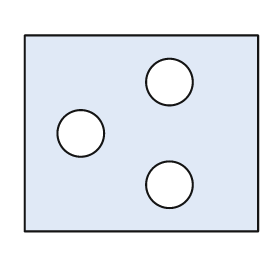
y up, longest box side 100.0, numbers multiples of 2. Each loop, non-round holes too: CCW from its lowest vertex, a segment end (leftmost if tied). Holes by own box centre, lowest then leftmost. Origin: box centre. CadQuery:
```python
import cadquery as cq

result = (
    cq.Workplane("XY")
    .moveTo(-50.0, -42.0)
    .lineTo(50.0, -42.0)
    .lineTo(50.0, 42.0)
    .lineTo(-50.0, 42.0)
    .close()
    .moveTo(12.0, -22.0)
    .circle(10.0)
    .moveTo(-26.0, 0.0)
    .circle(10.0)
    .moveTo(12.0, 22.0)
    .circle(10.0)
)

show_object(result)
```